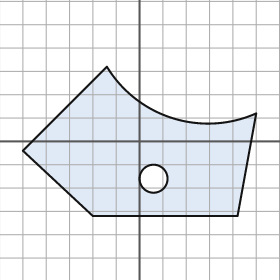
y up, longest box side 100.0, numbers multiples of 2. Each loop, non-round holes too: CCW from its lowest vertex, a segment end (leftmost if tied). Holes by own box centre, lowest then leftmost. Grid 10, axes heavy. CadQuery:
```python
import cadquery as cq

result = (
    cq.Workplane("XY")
    .moveTo(-20.0, -32.0)
    .lineTo(42.0, -32.0)
    .lineTo(50.0, 12.0)
    .threePointArc((14.0, 10.0), (-14.0, 32.0))
    .lineTo(-50.0, -4.0)
    .close()
    .moveTo(6.0, -16.0)
    .circle(6.0)
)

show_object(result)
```